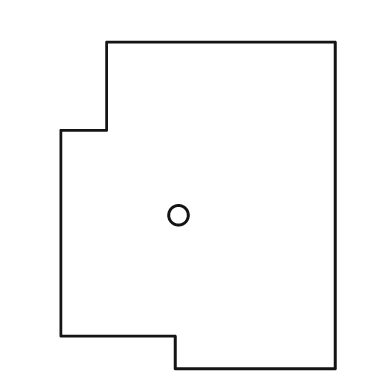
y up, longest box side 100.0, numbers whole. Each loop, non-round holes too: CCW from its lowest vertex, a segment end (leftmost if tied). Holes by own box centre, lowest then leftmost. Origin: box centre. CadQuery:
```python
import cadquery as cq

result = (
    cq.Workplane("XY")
    .moveTo(-7.0, -50.0)
    .lineTo(42.0, -50.0)
    .lineTo(42.0, 50.0)
    .lineTo(-28.0, 50.0)
    .lineTo(-28.0, 23.0)
    .lineTo(-42.0, 23.0)
    .lineTo(-42.0, -40.0)
    .lineTo(-7.0, -40.0)
    .close()
    .moveTo(-6.0, -3.0)
    .circle(3.0)
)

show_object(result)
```